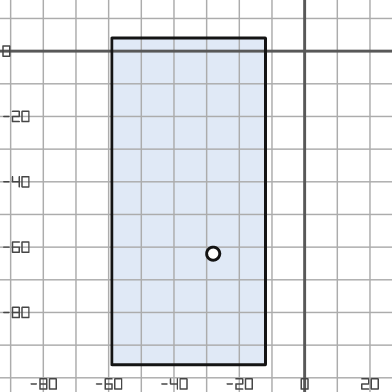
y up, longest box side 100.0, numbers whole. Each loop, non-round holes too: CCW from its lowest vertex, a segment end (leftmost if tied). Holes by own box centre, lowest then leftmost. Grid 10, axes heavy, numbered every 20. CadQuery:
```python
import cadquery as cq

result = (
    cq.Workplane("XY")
    .moveTo(-59.0, -96.0)
    .lineTo(-12.0, -96.0)
    .lineTo(-12.0, 4.0)
    .lineTo(-59.0, 4.0)
    .close()
    .moveTo(-28.0, -62.0)
    .circle(2.0)
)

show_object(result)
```